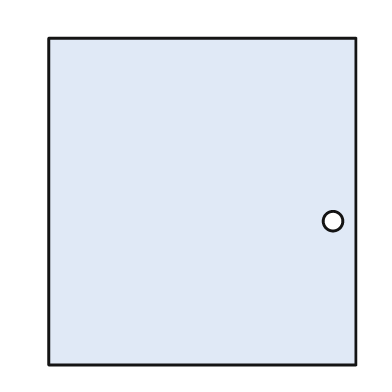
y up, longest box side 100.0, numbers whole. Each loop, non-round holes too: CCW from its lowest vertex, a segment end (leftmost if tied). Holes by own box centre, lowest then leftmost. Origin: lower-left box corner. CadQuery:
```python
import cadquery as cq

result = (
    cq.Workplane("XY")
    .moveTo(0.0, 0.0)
    .lineTo(94.0, 0.0)
    .lineTo(94.0, 100.0)
    .lineTo(0.0, 100.0)
    .close()
    .moveTo(87.0, 44.0)
    .circle(3.0)
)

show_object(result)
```